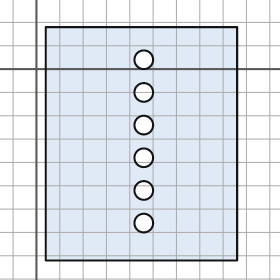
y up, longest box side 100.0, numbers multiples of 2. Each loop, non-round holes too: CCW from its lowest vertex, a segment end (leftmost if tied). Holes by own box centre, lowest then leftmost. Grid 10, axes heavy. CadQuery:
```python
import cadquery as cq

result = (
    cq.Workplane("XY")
    .moveTo(4.0, -82.0)
    .lineTo(86.0, -82.0)
    .lineTo(86.0, 18.0)
    .lineTo(4.0, 18.0)
    .close()
    .moveTo(46.0, -66.0)
    .circle(4.0)
    .moveTo(46.0, -52.0)
    .circle(4.0)
    .moveTo(46.0, -38.0)
    .circle(4.0)
    .moveTo(46.0, -24.0)
    .circle(4.0)
    .moveTo(46.0, -10.0)
    .circle(4.0)
    .moveTo(46.0, 4.0)
    .circle(4.0)
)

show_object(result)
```